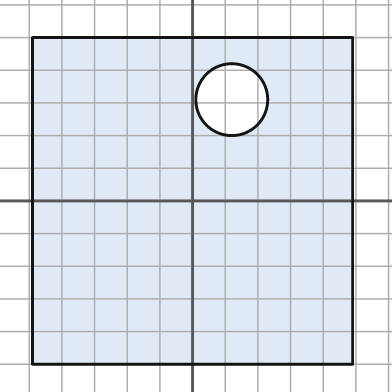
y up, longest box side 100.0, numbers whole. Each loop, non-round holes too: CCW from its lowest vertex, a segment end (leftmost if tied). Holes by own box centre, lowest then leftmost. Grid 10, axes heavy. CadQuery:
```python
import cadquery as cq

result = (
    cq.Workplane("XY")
    .moveTo(-49.0, -50.0)
    .lineTo(49.0, -50.0)
    .lineTo(49.0, 50.0)
    .lineTo(-49.0, 50.0)
    .close()
    .moveTo(12.0, 31.0)
    .circle(11.0)
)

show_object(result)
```